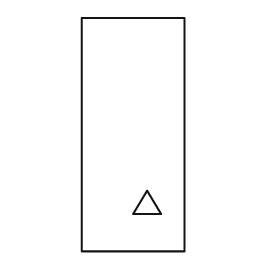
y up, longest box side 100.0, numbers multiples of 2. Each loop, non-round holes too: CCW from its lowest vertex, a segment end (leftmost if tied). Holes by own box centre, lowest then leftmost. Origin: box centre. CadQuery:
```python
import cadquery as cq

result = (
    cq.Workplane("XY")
    .moveTo(-22.0, -50.0)
    .lineTo(22.0, -50.0)
    .lineTo(22.0, 50.0)
    .lineTo(-22.0, 50.0)
    .close()
    .moveTo(0.0, -34.0)
    .lineTo(12.0, -34.0)
    .lineTo(6.0, -24.0)
    .close()
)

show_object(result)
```